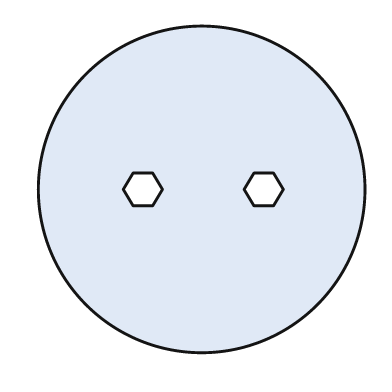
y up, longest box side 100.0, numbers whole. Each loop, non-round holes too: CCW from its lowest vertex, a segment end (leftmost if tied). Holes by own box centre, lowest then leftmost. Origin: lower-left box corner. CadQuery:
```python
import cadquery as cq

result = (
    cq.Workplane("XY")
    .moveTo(50.0, 50.0)
    .circle(50.0)
    .moveTo(29.0, 45.0)
    .lineTo(35.0, 45.0)
    .lineTo(38.0, 50.0)
    .lineTo(35.0, 55.0)
    .lineTo(29.0, 55.0)
    .lineTo(26.0, 50.0)
    .close()
    .moveTo(66.0, 45.0)
    .lineTo(72.0, 45.0)
    .lineTo(75.0, 50.0)
    .lineTo(72.0, 55.0)
    .lineTo(66.0, 55.0)
    .lineTo(63.0, 50.0)
    .close()
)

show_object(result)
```